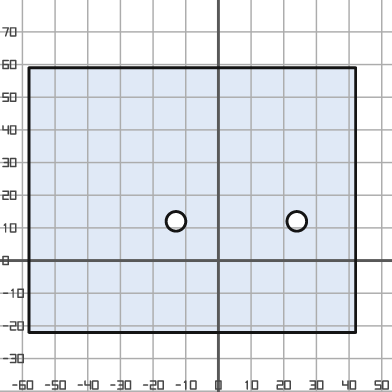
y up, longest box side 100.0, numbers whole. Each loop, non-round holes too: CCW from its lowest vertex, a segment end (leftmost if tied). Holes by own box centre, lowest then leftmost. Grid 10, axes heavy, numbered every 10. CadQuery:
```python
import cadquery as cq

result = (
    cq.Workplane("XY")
    .moveTo(-58.0, -22.0)
    .lineTo(42.0, -22.0)
    .lineTo(42.0, 59.0)
    .lineTo(-58.0, 59.0)
    .close()
    .moveTo(-13.0, 12.0)
    .circle(3.0)
    .moveTo(24.0, 12.0)
    .circle(3.0)
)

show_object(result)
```